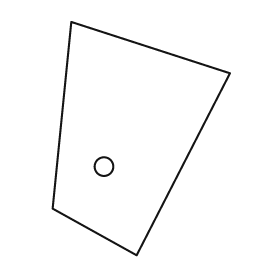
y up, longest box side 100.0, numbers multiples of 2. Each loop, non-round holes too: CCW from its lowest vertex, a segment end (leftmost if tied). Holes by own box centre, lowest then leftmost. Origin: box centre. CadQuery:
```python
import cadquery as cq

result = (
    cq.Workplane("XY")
    .moveTo(-2.0, -50.0)
    .lineTo(38.0, 28.0)
    .lineTo(-30.0, 50.0)
    .lineTo(-38.0, -30.0)
    .close()
    .moveTo(-16.0, -12.0)
    .circle(4.0)
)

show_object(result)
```